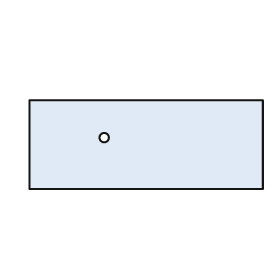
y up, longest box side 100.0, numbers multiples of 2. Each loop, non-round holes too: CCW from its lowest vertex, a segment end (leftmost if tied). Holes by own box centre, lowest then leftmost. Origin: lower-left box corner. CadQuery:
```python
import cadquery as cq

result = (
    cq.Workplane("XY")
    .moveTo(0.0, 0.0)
    .lineTo(100.0, 0.0)
    .lineTo(100.0, 38.0)
    .lineTo(0.0, 38.0)
    .close()
    .moveTo(32.0, 22.0)
    .circle(2.0)
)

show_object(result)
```